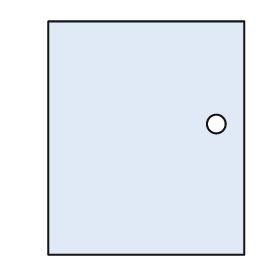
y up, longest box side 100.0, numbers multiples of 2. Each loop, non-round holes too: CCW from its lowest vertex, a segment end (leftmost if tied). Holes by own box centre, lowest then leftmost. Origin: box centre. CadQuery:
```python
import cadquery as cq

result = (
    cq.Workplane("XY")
    .moveTo(-42.0, -50.0)
    .lineTo(42.0, -50.0)
    .lineTo(42.0, 50.0)
    .lineTo(-42.0, 50.0)
    .close()
    .moveTo(30.0, 6.0)
    .circle(4.0)
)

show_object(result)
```